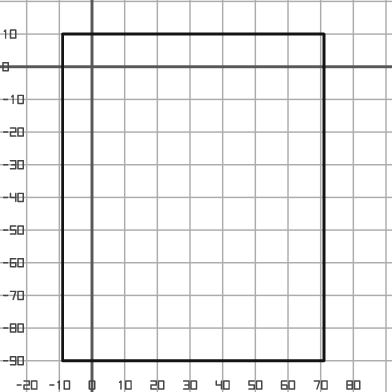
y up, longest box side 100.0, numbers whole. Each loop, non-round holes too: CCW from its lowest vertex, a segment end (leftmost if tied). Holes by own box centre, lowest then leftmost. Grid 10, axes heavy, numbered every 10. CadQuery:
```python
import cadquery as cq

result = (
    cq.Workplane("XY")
    .moveTo(-9.0, -90.0)
    .lineTo(71.0, -90.0)
    .lineTo(71.0, 10.0)
    .lineTo(-9.0, 10.0)
    .close()
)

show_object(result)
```